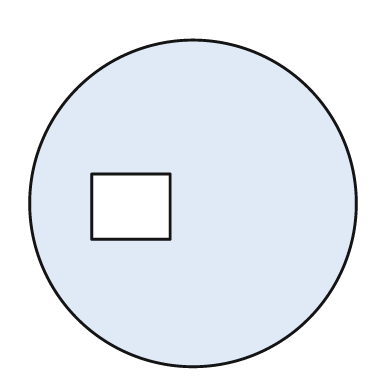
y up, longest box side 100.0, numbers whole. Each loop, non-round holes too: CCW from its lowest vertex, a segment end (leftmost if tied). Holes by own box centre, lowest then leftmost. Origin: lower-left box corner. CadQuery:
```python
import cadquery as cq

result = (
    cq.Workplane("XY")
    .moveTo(50.0, 50.0)
    .circle(50.0)
    .moveTo(19.0, 39.0)
    .lineTo(43.0, 39.0)
    .lineTo(43.0, 59.0)
    .lineTo(19.0, 59.0)
    .close()
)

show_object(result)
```